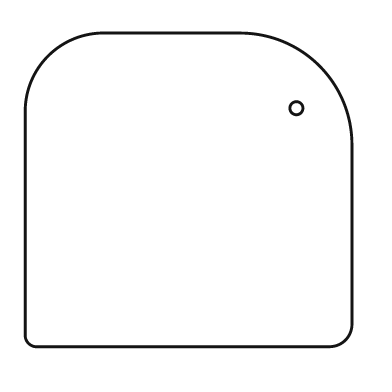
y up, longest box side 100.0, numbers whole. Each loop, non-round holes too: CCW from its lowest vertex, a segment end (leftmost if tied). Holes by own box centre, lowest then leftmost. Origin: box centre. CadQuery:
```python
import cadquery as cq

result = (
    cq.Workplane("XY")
    .moveTo(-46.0, -48.0)
    .lineTo(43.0, -48.0)
    .threePointArc((48.0, -46.0), (50.0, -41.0))
    .lineTo(50.0, 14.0)
    .threePointArc((40.0, 38.0), (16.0, 48.0))
    .lineTo(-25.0, 48.0)
    .threePointArc((-43.0, 41.0), (-50.0, 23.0))
    .lineTo(-50.0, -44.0)
    .threePointArc((-49.0, -47.0), (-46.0, -48.0))
    .close()
    .moveTo(33.0, 25.0)
    .circle(2.0)
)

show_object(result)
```